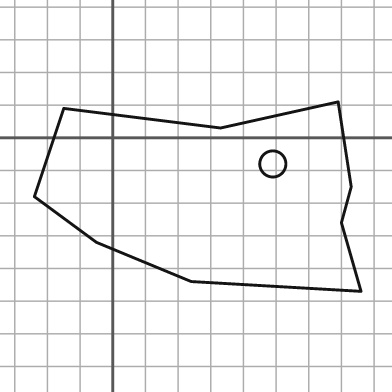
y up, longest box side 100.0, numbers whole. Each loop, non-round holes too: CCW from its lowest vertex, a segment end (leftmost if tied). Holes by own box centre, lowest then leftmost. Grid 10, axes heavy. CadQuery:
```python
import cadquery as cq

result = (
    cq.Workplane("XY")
    .moveTo(76.0, -47.0)
    .lineTo(70.0, -26.0)
    .lineTo(73.0, -15.0)
    .lineTo(69.0, 11.0)
    .lineTo(33.0, 3.0)
    .lineTo(-15.0, 9.0)
    .lineTo(-24.0, -18.0)
    .lineTo(-5.0, -32.0)
    .lineTo(24.0, -44.0)
    .close()
    .moveTo(49.0, -8.0)
    .circle(4.0)
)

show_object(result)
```